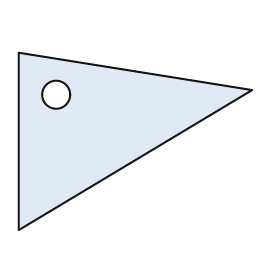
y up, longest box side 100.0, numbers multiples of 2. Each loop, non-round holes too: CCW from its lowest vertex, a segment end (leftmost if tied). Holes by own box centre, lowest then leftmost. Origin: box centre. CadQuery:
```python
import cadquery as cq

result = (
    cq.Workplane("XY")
    .moveTo(-50.0, -38.0)
    .lineTo(50.0, 22.0)
    .lineTo(-50.0, 38.0)
    .close()
    .moveTo(-34.0, 20.0)
    .circle(6.0)
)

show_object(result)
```